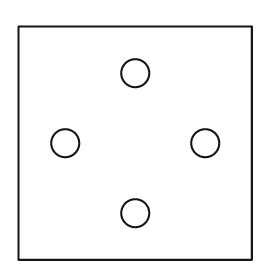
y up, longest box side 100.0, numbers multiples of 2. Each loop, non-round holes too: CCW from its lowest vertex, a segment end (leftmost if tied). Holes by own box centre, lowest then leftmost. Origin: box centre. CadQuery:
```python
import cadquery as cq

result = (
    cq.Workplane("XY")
    .moveTo(-50.0, -50.0)
    .lineTo(50.0, -50.0)
    .lineTo(50.0, 50.0)
    .lineTo(-50.0, 50.0)
    .close()
    .moveTo(0.0, -30.0)
    .circle(6.0)
    .moveTo(-30.0, 0.0)
    .circle(6.0)
    .moveTo(30.0, 0.0)
    .circle(6.0)
    .moveTo(0.0, 30.0)
    .circle(6.0)
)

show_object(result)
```